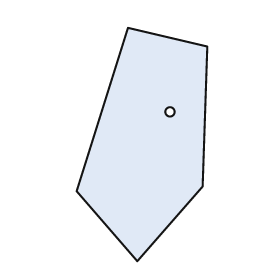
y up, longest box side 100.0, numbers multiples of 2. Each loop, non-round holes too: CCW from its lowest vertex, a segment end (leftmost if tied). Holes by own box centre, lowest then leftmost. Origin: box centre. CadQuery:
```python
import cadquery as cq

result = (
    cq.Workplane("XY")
    .moveTo(-2.0, -50.0)
    .lineTo(26.0, -18.0)
    .lineTo(28.0, 42.0)
    .lineTo(-6.0, 50.0)
    .lineTo(-28.0, -20.0)
    .close()
    .moveTo(12.0, 14.0)
    .circle(2.0)
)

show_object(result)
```